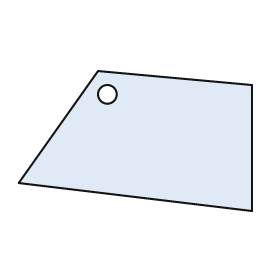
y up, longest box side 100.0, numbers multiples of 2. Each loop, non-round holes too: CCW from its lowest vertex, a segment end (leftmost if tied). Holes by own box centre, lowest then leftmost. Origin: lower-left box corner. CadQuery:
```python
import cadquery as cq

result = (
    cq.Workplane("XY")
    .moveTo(100.0, 0.0)
    .lineTo(100.0, 54.0)
    .lineTo(34.0, 60.0)
    .lineTo(0.0, 12.0)
    .close()
    .moveTo(38.0, 50.0)
    .circle(4.0)
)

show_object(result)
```